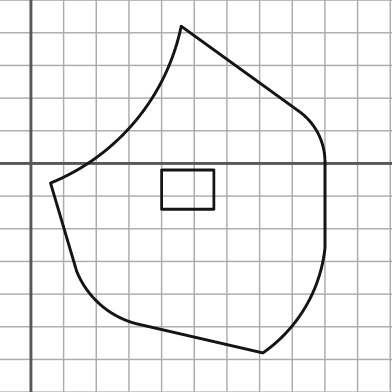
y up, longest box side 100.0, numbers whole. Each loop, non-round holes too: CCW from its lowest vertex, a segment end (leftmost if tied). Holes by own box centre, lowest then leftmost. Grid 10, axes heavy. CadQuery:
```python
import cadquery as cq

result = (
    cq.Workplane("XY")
    .moveTo(71.0, -58.0)
    .threePointArc((84.0, -44.0), (90.0, -26.0))
    .lineTo(90.0, 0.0)
    .threePointArc((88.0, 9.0), (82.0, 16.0))
    .lineTo(46.0, 42.0)
    .threePointArc((32.0, 13.0), (6.0, -6.0))
    .lineTo(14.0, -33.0)
    .threePointArc((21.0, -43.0), (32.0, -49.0))
    .close()
    .moveTo(40.0, -14.0)
    .lineTo(56.0, -14.0)
    .lineTo(56.0, -2.0)
    .lineTo(40.0, -2.0)
    .close()
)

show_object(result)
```